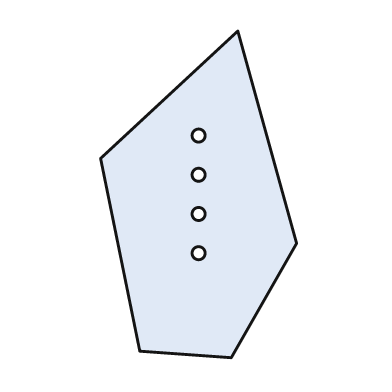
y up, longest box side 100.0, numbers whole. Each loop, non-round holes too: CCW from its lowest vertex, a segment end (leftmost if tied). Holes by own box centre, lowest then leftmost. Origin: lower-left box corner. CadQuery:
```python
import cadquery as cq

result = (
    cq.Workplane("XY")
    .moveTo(40.0, 0.0)
    .lineTo(60.0, 35.0)
    .lineTo(42.0, 100.0)
    .lineTo(0.0, 61.0)
    .lineTo(12.0, 2.0)
    .close()
    .moveTo(30.0, 32.0)
    .circle(2.0)
    .moveTo(30.0, 44.0)
    .circle(2.0)
    .moveTo(30.0, 56.0)
    .circle(2.0)
    .moveTo(30.0, 68.0)
    .circle(2.0)
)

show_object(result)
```